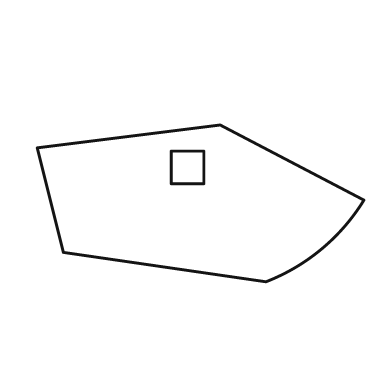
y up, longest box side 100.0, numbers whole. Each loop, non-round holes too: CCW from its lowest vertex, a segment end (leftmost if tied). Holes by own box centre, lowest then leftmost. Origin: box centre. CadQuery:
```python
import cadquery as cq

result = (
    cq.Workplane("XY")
    .moveTo(20.0, -24.0)
    .threePointArc((37.0, -14.0), (50.0, 1.0))
    .lineTo(6.0, 24.0)
    .lineTo(-50.0, 17.0)
    .lineTo(-42.0, -15.0)
    .close()
    .moveTo(-9.0, 6.0)
    .lineTo(1.0, 6.0)
    .lineTo(1.0, 16.0)
    .lineTo(-9.0, 16.0)
    .close()
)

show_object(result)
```